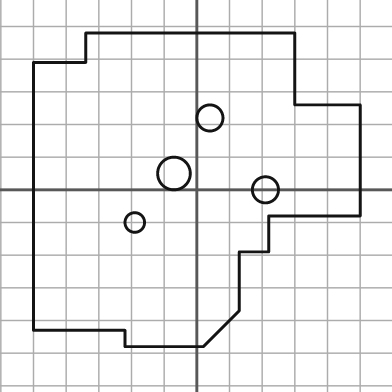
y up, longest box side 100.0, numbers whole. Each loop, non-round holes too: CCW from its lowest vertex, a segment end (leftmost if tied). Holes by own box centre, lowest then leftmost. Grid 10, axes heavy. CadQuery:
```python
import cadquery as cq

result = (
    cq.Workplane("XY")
    .moveTo(-22.0, -48.0)
    .lineTo(2.0, -48.0)
    .lineTo(13.0, -37.0)
    .lineTo(13.0, -19.0)
    .lineTo(22.0, -19.0)
    .lineTo(22.0, -8.0)
    .lineTo(50.0, -8.0)
    .lineTo(50.0, 26.0)
    .lineTo(30.0, 26.0)
    .lineTo(30.0, 48.0)
    .lineTo(-34.0, 48.0)
    .lineTo(-34.0, 39.0)
    .lineTo(-50.0, 39.0)
    .lineTo(-50.0, -43.0)
    .lineTo(-22.0, -43.0)
    .close()
    .moveTo(-19.0, -10.0)
    .circle(3.0)
    .moveTo(21.0, 0.0)
    .circle(4.0)
    .moveTo(-7.0, 5.0)
    .circle(5.0)
    .moveTo(4.0, 22.0)
    .circle(4.0)
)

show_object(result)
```